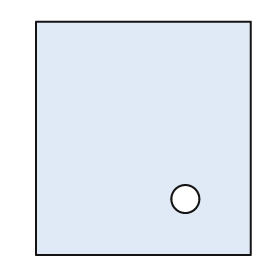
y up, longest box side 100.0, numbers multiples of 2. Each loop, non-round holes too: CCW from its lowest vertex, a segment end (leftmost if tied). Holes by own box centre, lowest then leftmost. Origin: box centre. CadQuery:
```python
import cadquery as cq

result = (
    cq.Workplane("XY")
    .moveTo(-46.0, -50.0)
    .lineTo(46.0, -50.0)
    .lineTo(46.0, 50.0)
    .lineTo(-46.0, 50.0)
    .close()
    .moveTo(18.0, -26.0)
    .circle(6.0)
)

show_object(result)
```